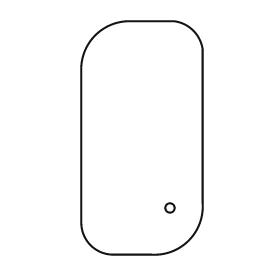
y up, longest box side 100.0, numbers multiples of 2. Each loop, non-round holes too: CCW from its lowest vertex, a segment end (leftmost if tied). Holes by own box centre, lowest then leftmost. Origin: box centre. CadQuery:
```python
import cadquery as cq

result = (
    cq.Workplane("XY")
    .moveTo(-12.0, -50.0)
    .lineTo(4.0, -50.0)
    .threePointArc((20.0, -44.0), (26.0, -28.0))
    .lineTo(26.0, 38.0)
    .threePointArc((22.0, 46.0), (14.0, 50.0))
    .lineTo(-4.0, 50.0)
    .threePointArc((-20.0, 44.0), (-26.0, 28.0))
    .lineTo(-26.0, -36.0)
    .threePointArc((-22.0, -46.0), (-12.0, -50.0))
    .close()
    .moveTo(12.0, -30.0)
    .circle(2.0)
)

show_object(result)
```